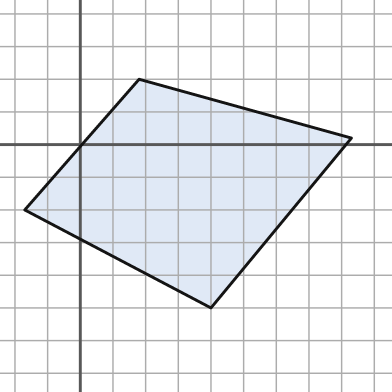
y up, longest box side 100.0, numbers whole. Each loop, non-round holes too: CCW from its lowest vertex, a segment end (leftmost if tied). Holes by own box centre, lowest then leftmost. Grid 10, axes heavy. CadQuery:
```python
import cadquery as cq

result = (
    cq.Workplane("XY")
    .moveTo(40.0, -50.0)
    .lineTo(83.0, 2.0)
    .lineTo(18.0, 20.0)
    .lineTo(-17.0, -20.0)
    .close()
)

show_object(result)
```